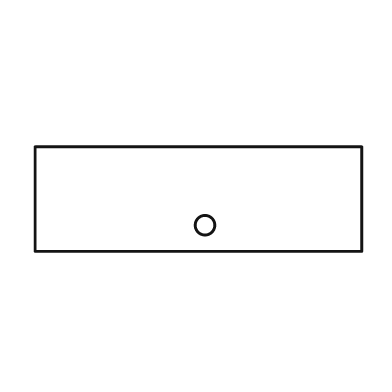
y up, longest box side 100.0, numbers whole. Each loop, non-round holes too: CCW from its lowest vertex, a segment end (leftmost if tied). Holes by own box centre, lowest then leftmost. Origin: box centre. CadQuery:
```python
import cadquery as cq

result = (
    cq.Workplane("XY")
    .moveTo(-50.0, -16.0)
    .lineTo(50.0, -16.0)
    .lineTo(50.0, 16.0)
    .lineTo(-50.0, 16.0)
    .close()
    .moveTo(2.0, -8.0)
    .circle(3.0)
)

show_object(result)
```